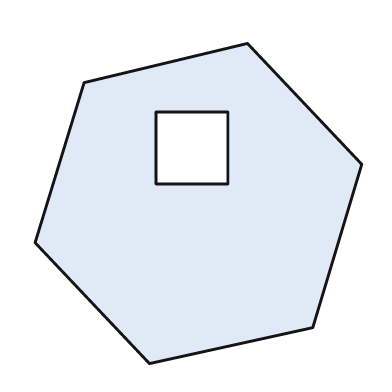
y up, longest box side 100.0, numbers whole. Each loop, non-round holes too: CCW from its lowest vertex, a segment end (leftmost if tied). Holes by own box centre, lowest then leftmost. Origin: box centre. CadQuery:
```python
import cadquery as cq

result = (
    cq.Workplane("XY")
    .moveTo(-15.0, -49.0)
    .lineTo(35.0, -38.0)
    .lineTo(50.0, 12.0)
    .lineTo(15.0, 49.0)
    .lineTo(-35.0, 37.0)
    .lineTo(-50.0, -12.0)
    .close()
    .moveTo(-13.0, 6.0)
    .lineTo(9.0, 6.0)
    .lineTo(9.0, 28.0)
    .lineTo(-13.0, 28.0)
    .close()
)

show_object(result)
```